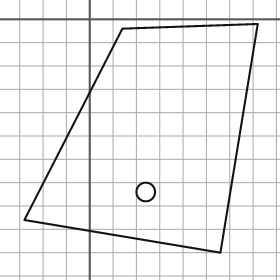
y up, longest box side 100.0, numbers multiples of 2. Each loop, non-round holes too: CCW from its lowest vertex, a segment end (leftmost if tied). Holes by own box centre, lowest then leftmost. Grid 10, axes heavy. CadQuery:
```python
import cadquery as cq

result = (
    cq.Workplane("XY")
    .moveTo(56.0, -100.0)
    .lineTo(72.0, -2.0)
    .lineTo(14.0, -4.0)
    .lineTo(-28.0, -86.0)
    .close()
    .moveTo(24.0, -74.0)
    .circle(4.0)
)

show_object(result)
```